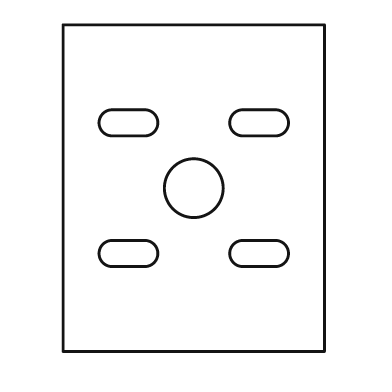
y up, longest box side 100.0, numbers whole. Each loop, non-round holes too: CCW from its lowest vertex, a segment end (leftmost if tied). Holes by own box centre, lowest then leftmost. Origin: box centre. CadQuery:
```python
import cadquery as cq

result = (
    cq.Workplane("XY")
    .moveTo(-40.0, -50.0)
    .lineTo(40.0, -50.0)
    .lineTo(40.0, 50.0)
    .lineTo(-40.0, 50.0)
    .close()
    .moveTo(-25.0, -24.0)
    .lineTo(-15.0, -24.0)
    .threePointArc((-11.0, -20.0), (-15.0, -16.0))
    .lineTo(-25.0, -16.0)
    .threePointArc((-29.0, -20.0), (-25.0, -24.0))
    .close()
    .moveTo(15.0, -24.0)
    .lineTo(25.0, -24.0)
    .threePointArc((29.0, -20.0), (25.0, -16.0))
    .lineTo(15.0, -16.0)
    .threePointArc((11.0, -20.0), (15.0, -24.0))
    .close()
    .moveTo(0.0, 0.0)
    .circle(9.0)
    .moveTo(-25.0, 16.0)
    .lineTo(-15.0, 16.0)
    .threePointArc((-11.0, 20.0), (-15.0, 24.0))
    .lineTo(-25.0, 24.0)
    .threePointArc((-29.0, 20.0), (-25.0, 16.0))
    .close()
    .moveTo(15.0, 16.0)
    .lineTo(25.0, 16.0)
    .threePointArc((29.0, 20.0), (25.0, 24.0))
    .lineTo(15.0, 24.0)
    .threePointArc((11.0, 20.0), (15.0, 16.0))
    .close()
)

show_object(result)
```